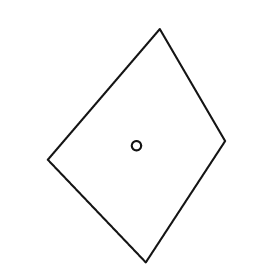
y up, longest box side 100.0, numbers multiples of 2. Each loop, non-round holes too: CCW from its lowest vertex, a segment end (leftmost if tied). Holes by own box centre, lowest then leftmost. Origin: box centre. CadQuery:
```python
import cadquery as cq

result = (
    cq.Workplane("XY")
    .moveTo(4.0, -50.0)
    .lineTo(38.0, 2.0)
    .lineTo(10.0, 50.0)
    .lineTo(-38.0, -6.0)
    .close()
    .moveTo(0.0, 0.0)
    .circle(2.0)
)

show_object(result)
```